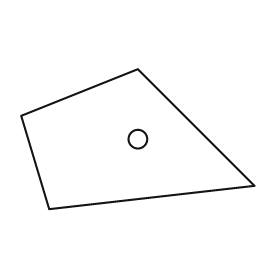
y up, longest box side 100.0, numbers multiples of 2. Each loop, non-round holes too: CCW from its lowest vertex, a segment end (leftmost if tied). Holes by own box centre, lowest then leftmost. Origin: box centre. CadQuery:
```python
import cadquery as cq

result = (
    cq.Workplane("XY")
    .moveTo(-38.0, -30.0)
    .lineTo(50.0, -20.0)
    .lineTo(0.0, 30.0)
    .lineTo(-50.0, 10.0)
    .close()
    .moveTo(0.0, 0.0)
    .circle(4.0)
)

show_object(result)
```